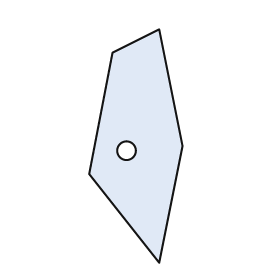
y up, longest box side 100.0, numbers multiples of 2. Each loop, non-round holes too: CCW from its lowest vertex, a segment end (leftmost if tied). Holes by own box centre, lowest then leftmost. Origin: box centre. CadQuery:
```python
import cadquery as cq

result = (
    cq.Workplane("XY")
    .moveTo(10.0, -50.0)
    .lineTo(20.0, 0.0)
    .lineTo(10.0, 50.0)
    .lineTo(-10.0, 40.0)
    .lineTo(-20.0, -12.0)
    .close()
    .moveTo(-4.0, -2.0)
    .circle(4.0)
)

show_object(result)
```